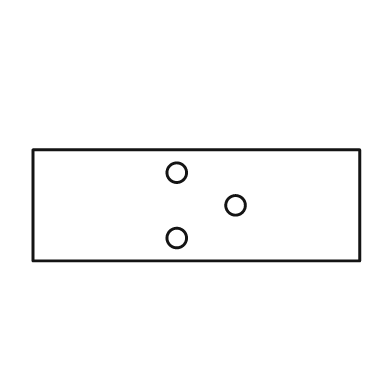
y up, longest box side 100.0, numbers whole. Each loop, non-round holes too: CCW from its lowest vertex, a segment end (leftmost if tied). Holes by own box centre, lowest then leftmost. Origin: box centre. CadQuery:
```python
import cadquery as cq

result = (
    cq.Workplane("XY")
    .moveTo(-50.0, -17.0)
    .lineTo(50.0, -17.0)
    .lineTo(50.0, 17.0)
    .lineTo(-50.0, 17.0)
    .close()
    .moveTo(-6.0, -10.0)
    .circle(3.0)
    .moveTo(12.0, 0.0)
    .circle(3.0)
    .moveTo(-6.0, 10.0)
    .circle(3.0)
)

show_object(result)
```